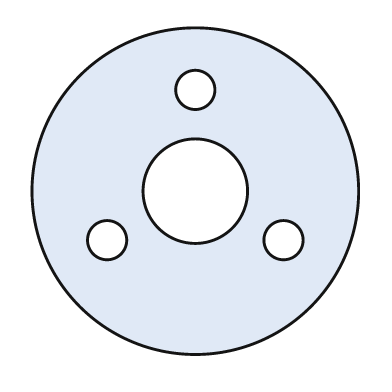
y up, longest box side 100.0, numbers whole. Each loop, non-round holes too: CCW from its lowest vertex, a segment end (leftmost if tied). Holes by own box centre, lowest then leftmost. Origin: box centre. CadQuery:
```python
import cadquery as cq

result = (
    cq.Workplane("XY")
    .moveTo(0.0, 0.0)
    .circle(50.0)
    .moveTo(-27.0, -15.0)
    .circle(6.0)
    .moveTo(27.0, -15.0)
    .circle(6.0)
    .moveTo(0.0, 0.0)
    .circle(16.0)
    .moveTo(0.0, 31.0)
    .circle(6.0)
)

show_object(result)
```